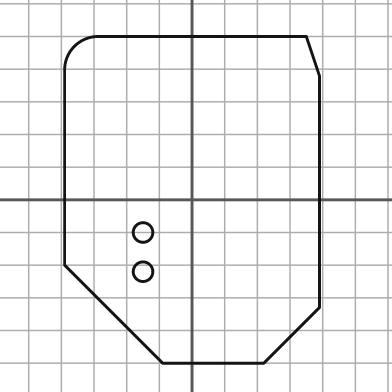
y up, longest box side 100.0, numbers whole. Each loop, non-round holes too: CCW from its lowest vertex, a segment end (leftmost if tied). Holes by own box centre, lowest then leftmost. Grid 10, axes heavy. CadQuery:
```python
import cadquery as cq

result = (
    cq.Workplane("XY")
    .moveTo(-9.0, -50.0)
    .lineTo(22.0, -50.0)
    .lineTo(39.0, -33.0)
    .lineTo(39.0, 38.0)
    .lineTo(35.0, 50.0)
    .lineTo(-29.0, 50.0)
    .threePointArc((-36.0, 47.0), (-39.0, 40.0))
    .lineTo(-39.0, -20.0)
    .close()
    .moveTo(-15.0, -22.0)
    .circle(3.0)
    .moveTo(-15.0, -10.0)
    .circle(3.0)
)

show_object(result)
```